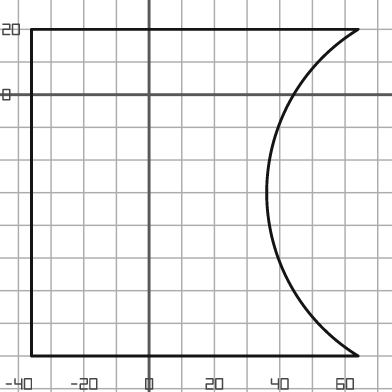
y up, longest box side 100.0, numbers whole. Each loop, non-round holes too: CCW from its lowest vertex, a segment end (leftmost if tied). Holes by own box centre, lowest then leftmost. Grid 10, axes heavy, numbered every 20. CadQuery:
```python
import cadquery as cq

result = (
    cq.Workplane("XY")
    .moveTo(-36.0, -80.0)
    .lineTo(64.0, -80.0)
    .threePointArc((36.0, -30.0), (64.0, 20.0))
    .lineTo(-36.0, 20.0)
    .close()
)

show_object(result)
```